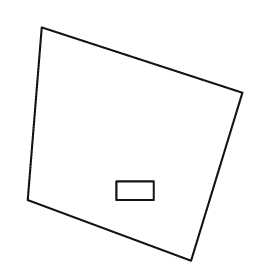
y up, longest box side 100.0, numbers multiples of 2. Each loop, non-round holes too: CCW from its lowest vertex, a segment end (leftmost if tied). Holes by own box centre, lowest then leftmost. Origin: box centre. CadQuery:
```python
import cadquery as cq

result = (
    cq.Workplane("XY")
    .moveTo(24.0, -50.0)
    .lineTo(46.0, 22.0)
    .lineTo(-40.0, 50.0)
    .lineTo(-46.0, -24.0)
    .close()
    .moveTo(-8.0, -24.0)
    .lineTo(8.0, -24.0)
    .lineTo(8.0, -16.0)
    .lineTo(-8.0, -16.0)
    .close()
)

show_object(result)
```